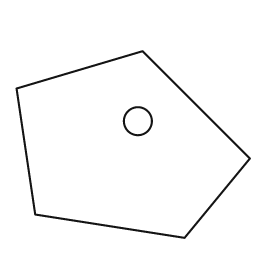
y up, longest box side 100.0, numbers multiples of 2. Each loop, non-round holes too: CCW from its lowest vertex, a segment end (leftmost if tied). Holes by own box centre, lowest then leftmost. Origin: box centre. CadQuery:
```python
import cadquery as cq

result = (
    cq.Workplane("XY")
    .moveTo(22.0, -40.0)
    .lineTo(50.0, -6.0)
    .lineTo(4.0, 40.0)
    .lineTo(-50.0, 24.0)
    .lineTo(-42.0, -30.0)
    .close()
    .moveTo(2.0, 10.0)
    .circle(6.0)
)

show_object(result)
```